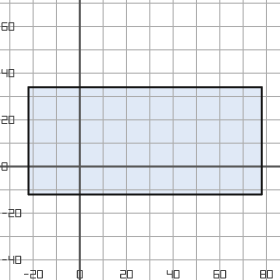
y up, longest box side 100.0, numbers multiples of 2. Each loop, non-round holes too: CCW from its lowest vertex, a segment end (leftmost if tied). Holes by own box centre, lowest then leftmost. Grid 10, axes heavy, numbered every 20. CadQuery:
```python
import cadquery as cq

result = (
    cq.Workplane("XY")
    .moveTo(-22.0, -12.0)
    .lineTo(78.0, -12.0)
    .lineTo(78.0, 34.0)
    .lineTo(-22.0, 34.0)
    .close()
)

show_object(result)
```